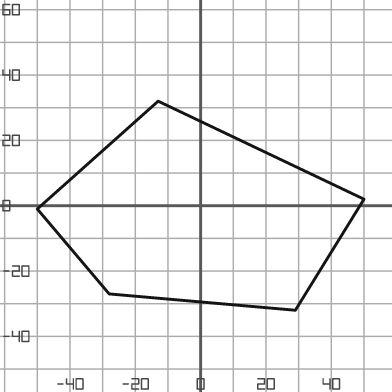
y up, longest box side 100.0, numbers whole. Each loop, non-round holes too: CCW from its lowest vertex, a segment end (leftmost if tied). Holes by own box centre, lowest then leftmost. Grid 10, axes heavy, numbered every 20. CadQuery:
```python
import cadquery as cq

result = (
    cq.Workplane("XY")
    .moveTo(29.0, -32.0)
    .lineTo(50.0, 2.0)
    .lineTo(-13.0, 32.0)
    .lineTo(-50.0, -1.0)
    .lineTo(-28.0, -27.0)
    .close()
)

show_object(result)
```